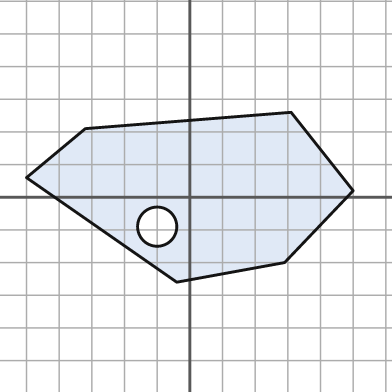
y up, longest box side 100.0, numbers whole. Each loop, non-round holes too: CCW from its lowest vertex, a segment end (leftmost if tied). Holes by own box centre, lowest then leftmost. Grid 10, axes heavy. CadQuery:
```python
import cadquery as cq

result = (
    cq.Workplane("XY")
    .moveTo(-4.0, -26.0)
    .lineTo(29.0, -20.0)
    .lineTo(50.0, 2.0)
    .lineTo(31.0, 26.0)
    .lineTo(-32.0, 21.0)
    .lineTo(-50.0, 6.0)
    .close()
    .moveTo(-10.0, -9.0)
    .circle(6.0)
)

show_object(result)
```